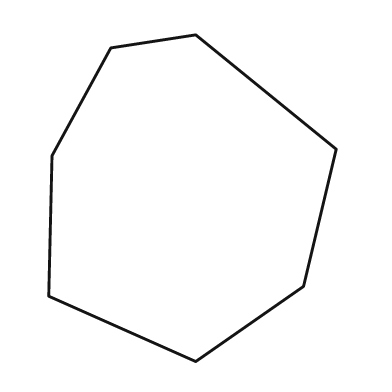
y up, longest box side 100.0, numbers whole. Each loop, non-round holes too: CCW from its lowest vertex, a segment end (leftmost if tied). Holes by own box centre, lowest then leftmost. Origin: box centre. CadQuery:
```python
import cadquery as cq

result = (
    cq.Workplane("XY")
    .moveTo(1.0, -50.0)
    .lineTo(34.0, -27.0)
    .lineTo(44.0, 15.0)
    .lineTo(1.0, 50.0)
    .lineTo(-25.0, 46.0)
    .lineTo(-43.0, 13.0)
    .lineTo(-44.0, -30.0)
    .close()
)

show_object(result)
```